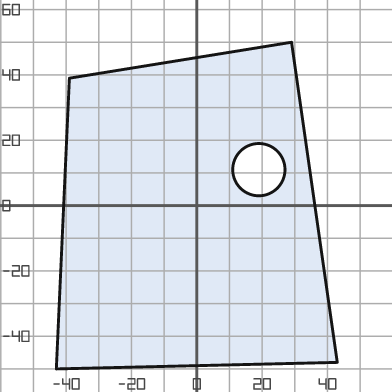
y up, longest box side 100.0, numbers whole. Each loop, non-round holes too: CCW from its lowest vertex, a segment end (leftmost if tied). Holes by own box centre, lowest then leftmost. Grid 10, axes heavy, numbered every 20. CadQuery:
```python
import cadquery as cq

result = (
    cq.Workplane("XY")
    .moveTo(-43.0, -50.0)
    .lineTo(43.0, -48.0)
    .lineTo(29.0, 50.0)
    .lineTo(-39.0, 39.0)
    .close()
    .moveTo(19.0, 11.0)
    .circle(8.0)
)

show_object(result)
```